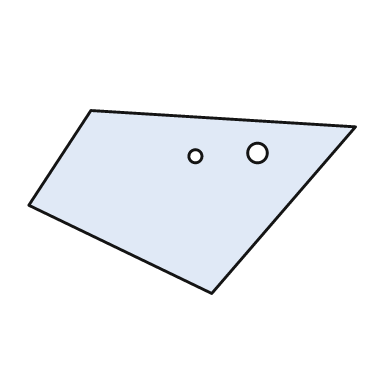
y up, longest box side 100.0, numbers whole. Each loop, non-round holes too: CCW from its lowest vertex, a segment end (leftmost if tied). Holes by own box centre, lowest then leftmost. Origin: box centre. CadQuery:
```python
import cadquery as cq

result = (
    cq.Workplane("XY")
    .moveTo(6.0, -28.0)
    .lineTo(50.0, 23.0)
    .lineTo(-31.0, 28.0)
    .lineTo(-50.0, -1.0)
    .close()
    .moveTo(1.0, 14.0)
    .circle(2.0)
    .moveTo(20.0, 15.0)
    .circle(3.0)
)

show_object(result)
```